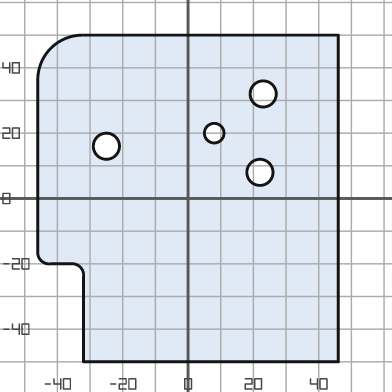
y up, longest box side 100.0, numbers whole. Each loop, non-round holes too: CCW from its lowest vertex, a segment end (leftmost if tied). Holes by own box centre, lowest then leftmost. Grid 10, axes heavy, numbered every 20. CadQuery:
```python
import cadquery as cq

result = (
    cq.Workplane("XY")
    .moveTo(-32.0, -50.0)
    .lineTo(46.0, -50.0)
    .lineTo(46.0, 50.0)
    .lineTo(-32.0, 50.0)
    .threePointArc((-42.0, 46.0), (-46.0, 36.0))
    .lineTo(-46.0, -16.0)
    .threePointArc((-45.0, -19.0), (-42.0, -20.0))
    .lineTo(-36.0, -20.0)
    .threePointArc((-33.0, -21.0), (-32.0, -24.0))
    .close()
    .moveTo(22.0, 8.0)
    .circle(4.0)
    .moveTo(-25.0, 16.0)
    .circle(4.0)
    .moveTo(8.0, 20.0)
    .circle(3.0)
    .moveTo(23.0, 32.0)
    .circle(4.0)
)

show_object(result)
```